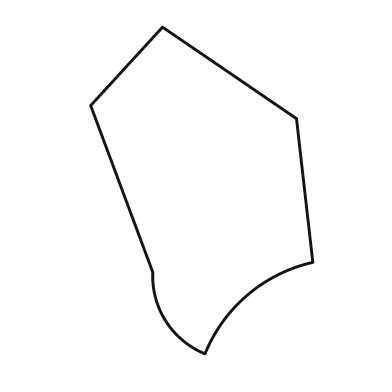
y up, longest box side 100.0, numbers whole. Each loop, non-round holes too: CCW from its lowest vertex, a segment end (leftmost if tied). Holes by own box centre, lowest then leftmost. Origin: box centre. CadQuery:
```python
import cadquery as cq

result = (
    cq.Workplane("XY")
    .moveTo(1.0, -50.0)
    .threePointArc((14.0, -32.0), (34.0, -22.0))
    .lineTo(29.0, 22.0)
    .lineTo(-12.0, 50.0)
    .lineTo(-34.0, 26.0)
    .lineTo(-15.0, -25.0)
    .threePointArc((-11.0, -40.0), (1.0, -50.0))
    .close()
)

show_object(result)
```